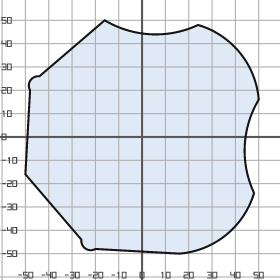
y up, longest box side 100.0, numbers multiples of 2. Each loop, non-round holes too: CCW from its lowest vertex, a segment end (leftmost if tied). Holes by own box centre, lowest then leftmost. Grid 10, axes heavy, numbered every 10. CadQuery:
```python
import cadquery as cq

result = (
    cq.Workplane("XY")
    .moveTo(16.0, -50.0)
    .threePointArc((36.0, -42.0), (48.0, -24.0))
    .threePointArc((44.0, -4.0), (50.0, 16.0))
    .threePointArc((42.0, 36.0), (24.0, 48.0))
    .threePointArc((4.0, 44.0), (-16.0, 50.0))
    .lineTo(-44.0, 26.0)
    .threePointArc((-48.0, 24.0), (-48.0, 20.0))
    .lineTo(-50.0, -16.0)
    .lineTo(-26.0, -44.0)
    .threePointArc((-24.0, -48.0), (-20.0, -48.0))
    .close()
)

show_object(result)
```